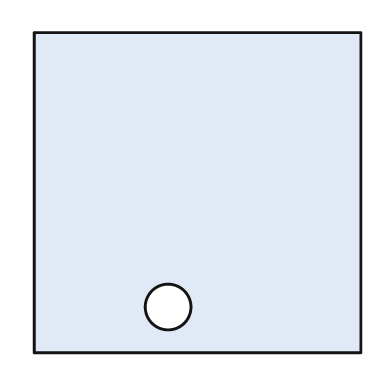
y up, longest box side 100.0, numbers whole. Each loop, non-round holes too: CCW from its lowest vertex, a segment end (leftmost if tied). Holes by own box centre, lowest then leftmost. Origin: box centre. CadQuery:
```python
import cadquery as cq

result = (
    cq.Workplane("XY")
    .moveTo(-50.0, -49.0)
    .lineTo(50.0, -49.0)
    .lineTo(50.0, 49.0)
    .lineTo(-50.0, 49.0)
    .close()
    .moveTo(-9.0, -35.0)
    .circle(7.0)
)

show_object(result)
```